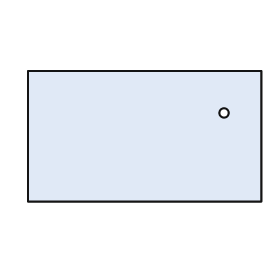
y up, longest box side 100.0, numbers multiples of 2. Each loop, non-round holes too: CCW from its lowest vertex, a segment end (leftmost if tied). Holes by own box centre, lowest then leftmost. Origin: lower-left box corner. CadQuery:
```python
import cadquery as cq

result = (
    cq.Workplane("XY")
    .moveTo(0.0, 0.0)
    .lineTo(100.0, 0.0)
    .lineTo(100.0, 56.0)
    .lineTo(0.0, 56.0)
    .close()
    .moveTo(84.0, 38.0)
    .circle(2.0)
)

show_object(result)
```